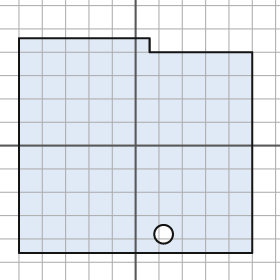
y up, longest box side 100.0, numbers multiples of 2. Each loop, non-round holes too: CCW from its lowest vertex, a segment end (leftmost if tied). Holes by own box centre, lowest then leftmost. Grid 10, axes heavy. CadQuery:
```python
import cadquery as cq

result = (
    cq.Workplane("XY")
    .moveTo(-50.0, -46.0)
    .lineTo(50.0, -46.0)
    .lineTo(50.0, 40.0)
    .lineTo(6.0, 40.0)
    .lineTo(6.0, 46.0)
    .lineTo(-50.0, 46.0)
    .close()
    .moveTo(12.0, -38.0)
    .circle(4.0)
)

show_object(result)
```